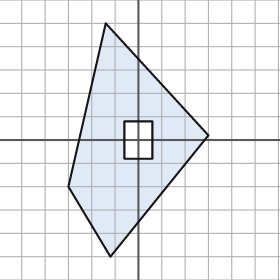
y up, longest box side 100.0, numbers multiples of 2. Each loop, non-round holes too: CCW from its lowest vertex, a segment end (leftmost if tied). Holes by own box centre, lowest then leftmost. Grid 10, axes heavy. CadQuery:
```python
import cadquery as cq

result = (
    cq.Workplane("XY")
    .moveTo(-12.0, -50.0)
    .lineTo(30.0, 2.0)
    .lineTo(-14.0, 50.0)
    .lineTo(-30.0, -20.0)
    .close()
    .moveTo(-6.0, -8.0)
    .lineTo(6.0, -8.0)
    .lineTo(6.0, 8.0)
    .lineTo(-6.0, 8.0)
    .close()
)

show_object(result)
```